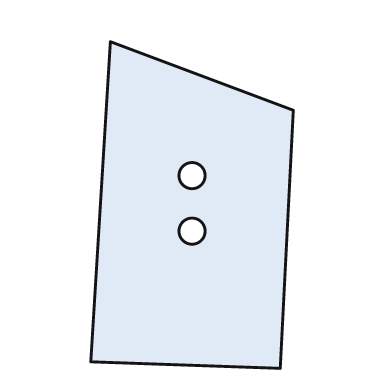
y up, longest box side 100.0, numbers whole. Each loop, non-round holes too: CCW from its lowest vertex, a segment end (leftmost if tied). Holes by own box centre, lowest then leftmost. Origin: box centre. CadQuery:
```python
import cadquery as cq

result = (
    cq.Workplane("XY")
    .moveTo(27.0, -50.0)
    .lineTo(31.0, 29.0)
    .lineTo(-25.0, 50.0)
    .lineTo(-31.0, -48.0)
    .close()
    .moveTo(0.0, -8.0)
    .circle(4.0)
    .moveTo(0.0, 9.0)
    .circle(4.0)
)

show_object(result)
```